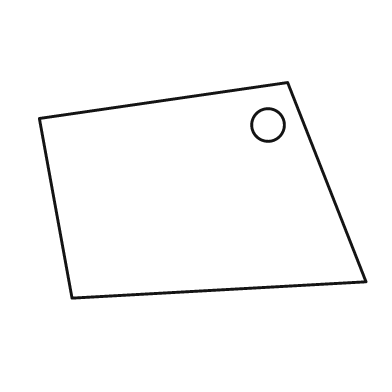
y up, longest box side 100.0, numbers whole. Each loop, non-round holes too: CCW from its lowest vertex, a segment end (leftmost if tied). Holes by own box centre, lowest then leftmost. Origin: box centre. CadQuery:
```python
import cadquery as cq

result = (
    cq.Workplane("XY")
    .moveTo(-40.0, -33.0)
    .lineTo(50.0, -28.0)
    .lineTo(26.0, 33.0)
    .lineTo(-50.0, 22.0)
    .close()
    .moveTo(20.0, 20.0)
    .circle(5.0)
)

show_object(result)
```